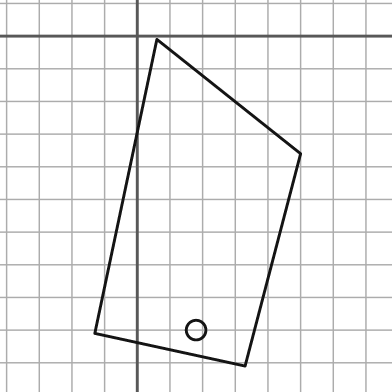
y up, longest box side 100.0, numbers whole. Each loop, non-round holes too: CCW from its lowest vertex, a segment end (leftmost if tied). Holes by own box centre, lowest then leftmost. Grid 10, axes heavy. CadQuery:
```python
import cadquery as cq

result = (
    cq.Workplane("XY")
    .moveTo(33.0, -101.0)
    .lineTo(50.0, -36.0)
    .lineTo(6.0, -1.0)
    .lineTo(-13.0, -91.0)
    .close()
    .moveTo(18.0, -90.0)
    .circle(3.0)
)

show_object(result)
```